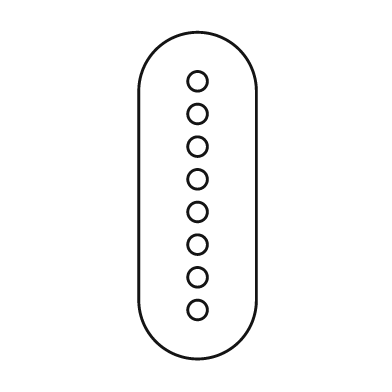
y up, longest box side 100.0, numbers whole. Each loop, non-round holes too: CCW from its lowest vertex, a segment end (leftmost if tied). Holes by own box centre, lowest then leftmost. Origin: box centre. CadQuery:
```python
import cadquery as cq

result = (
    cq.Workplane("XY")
    .moveTo(-18.0, -32.0)
    .threePointArc((0.0, -50.0), (18.0, -32.0))
    .lineTo(18.0, 32.0)
    .threePointArc((0.0, 50.0), (-18.0, 32.0))
    .close()
    .moveTo(0.0, -35.0)
    .circle(3.0)
    .moveTo(0.0, -25.0)
    .circle(3.0)
    .moveTo(0.0, -15.0)
    .circle(3.0)
    .moveTo(0.0, -5.0)
    .circle(3.0)
    .moveTo(0.0, 5.0)
    .circle(3.0)
    .moveTo(0.0, 15.0)
    .circle(3.0)
    .moveTo(0.0, 25.0)
    .circle(3.0)
    .moveTo(0.0, 35.0)
    .circle(3.0)
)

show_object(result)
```